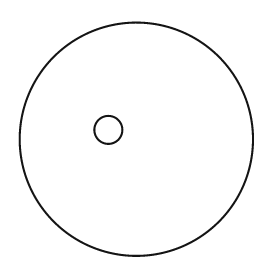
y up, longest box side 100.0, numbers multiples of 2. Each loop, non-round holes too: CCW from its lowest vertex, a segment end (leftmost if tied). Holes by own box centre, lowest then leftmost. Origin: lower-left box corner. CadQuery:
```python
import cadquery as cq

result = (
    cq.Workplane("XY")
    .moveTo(50.0, 50.0)
    .circle(50.0)
    .moveTo(38.0, 54.0)
    .circle(6.0)
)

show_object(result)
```